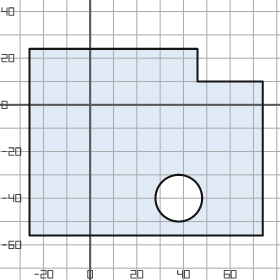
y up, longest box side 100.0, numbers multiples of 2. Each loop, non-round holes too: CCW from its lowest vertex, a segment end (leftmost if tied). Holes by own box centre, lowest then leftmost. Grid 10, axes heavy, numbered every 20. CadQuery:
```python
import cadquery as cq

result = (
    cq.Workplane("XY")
    .moveTo(-26.0, -56.0)
    .lineTo(74.0, -56.0)
    .lineTo(74.0, 10.0)
    .lineTo(46.0, 10.0)
    .lineTo(46.0, 24.0)
    .lineTo(-26.0, 24.0)
    .close()
    .moveTo(38.0, -40.0)
    .circle(10.0)
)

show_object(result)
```